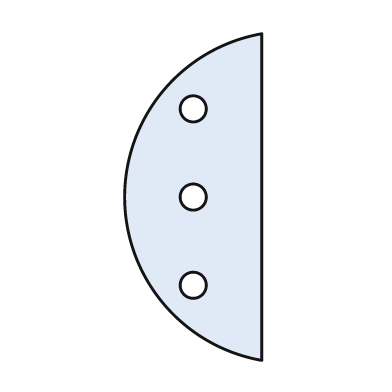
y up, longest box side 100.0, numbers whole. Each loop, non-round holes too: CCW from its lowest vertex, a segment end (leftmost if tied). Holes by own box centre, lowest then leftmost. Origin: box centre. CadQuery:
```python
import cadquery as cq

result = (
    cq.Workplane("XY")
    .moveTo(21.0, -50.0)
    .lineTo(21.0, 50.0)
    .threePointArc((-21.0, 0.0), (21.0, -50.0))
    .close()
    .moveTo(0.0, -27.0)
    .circle(4.0)
    .moveTo(0.0, 0.0)
    .circle(4.0)
    .moveTo(0.0, 27.0)
    .circle(4.0)
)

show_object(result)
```